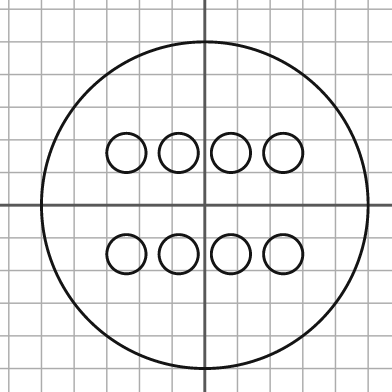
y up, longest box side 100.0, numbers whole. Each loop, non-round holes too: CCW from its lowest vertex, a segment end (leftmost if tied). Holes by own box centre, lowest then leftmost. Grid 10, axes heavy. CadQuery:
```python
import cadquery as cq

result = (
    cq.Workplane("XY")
    .moveTo(0.0, 0.0)
    .circle(50.0)
    .moveTo(-24.0, -15.0)
    .circle(6.0)
    .moveTo(-8.0, -15.0)
    .circle(6.0)
    .moveTo(8.0, -15.0)
    .circle(6.0)
    .moveTo(24.0, -15.0)
    .circle(6.0)
    .moveTo(-24.0, 16.0)
    .circle(6.0)
    .moveTo(-8.0, 16.0)
    .circle(6.0)
    .moveTo(8.0, 16.0)
    .circle(6.0)
    .moveTo(24.0, 16.0)
    .circle(6.0)
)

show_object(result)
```